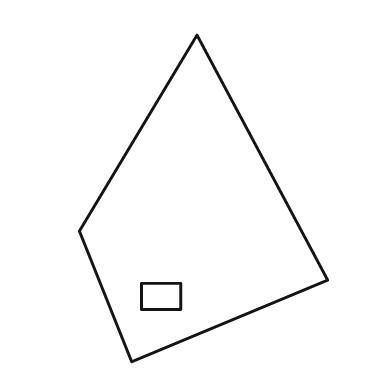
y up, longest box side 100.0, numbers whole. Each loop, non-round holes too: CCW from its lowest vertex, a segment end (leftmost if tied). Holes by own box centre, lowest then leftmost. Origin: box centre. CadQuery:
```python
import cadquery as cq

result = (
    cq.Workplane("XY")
    .moveTo(-22.0, -50.0)
    .lineTo(38.0, -25.0)
    .lineTo(-2.0, 50.0)
    .lineTo(-38.0, -10.0)
    .close()
    .moveTo(-19.0, -34.0)
    .lineTo(-7.0, -34.0)
    .lineTo(-7.0, -26.0)
    .lineTo(-19.0, -26.0)
    .close()
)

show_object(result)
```